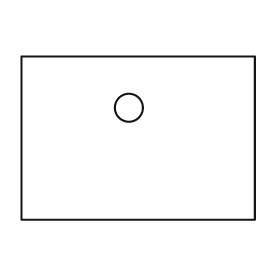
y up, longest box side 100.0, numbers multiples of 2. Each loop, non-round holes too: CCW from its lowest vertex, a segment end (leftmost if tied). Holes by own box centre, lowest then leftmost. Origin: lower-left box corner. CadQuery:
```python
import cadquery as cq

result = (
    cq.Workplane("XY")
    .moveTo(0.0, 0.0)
    .lineTo(100.0, 0.0)
    .lineTo(100.0, 70.0)
    .lineTo(0.0, 70.0)
    .close()
    .moveTo(46.0, 48.0)
    .circle(6.0)
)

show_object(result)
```